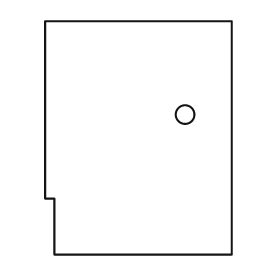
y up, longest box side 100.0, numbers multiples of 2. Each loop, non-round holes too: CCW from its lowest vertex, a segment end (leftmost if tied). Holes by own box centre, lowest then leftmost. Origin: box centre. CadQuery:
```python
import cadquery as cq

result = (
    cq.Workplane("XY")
    .moveTo(-36.0, -50.0)
    .lineTo(40.0, -50.0)
    .lineTo(40.0, 50.0)
    .lineTo(-40.0, 50.0)
    .lineTo(-40.0, -26.0)
    .lineTo(-36.0, -26.0)
    .close()
    .moveTo(20.0, 10.0)
    .circle(4.0)
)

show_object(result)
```